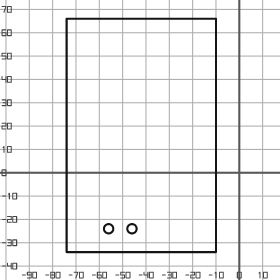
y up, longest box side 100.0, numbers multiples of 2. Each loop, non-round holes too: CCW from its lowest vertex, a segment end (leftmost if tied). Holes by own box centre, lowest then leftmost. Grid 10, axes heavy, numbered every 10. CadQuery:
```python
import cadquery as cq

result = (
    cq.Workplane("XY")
    .moveTo(-74.0, -34.0)
    .lineTo(-10.0, -34.0)
    .lineTo(-10.0, 66.0)
    .lineTo(-74.0, 66.0)
    .close()
    .moveTo(-56.0, -24.0)
    .circle(2.0)
    .moveTo(-46.0, -24.0)
    .circle(2.0)
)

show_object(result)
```